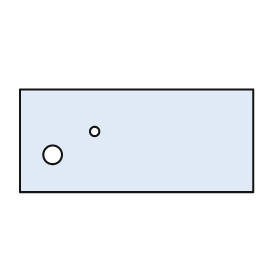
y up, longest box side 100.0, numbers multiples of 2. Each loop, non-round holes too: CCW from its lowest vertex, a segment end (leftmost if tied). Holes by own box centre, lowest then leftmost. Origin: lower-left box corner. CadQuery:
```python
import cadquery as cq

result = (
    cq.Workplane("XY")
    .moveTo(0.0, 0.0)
    .lineTo(100.0, 0.0)
    .lineTo(100.0, 44.0)
    .lineTo(0.0, 44.0)
    .close()
    .moveTo(14.0, 16.0)
    .circle(4.0)
    .moveTo(32.0, 26.0)
    .circle(2.0)
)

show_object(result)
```